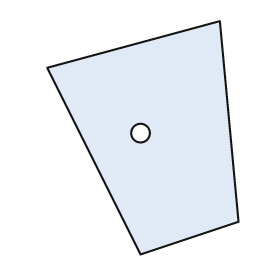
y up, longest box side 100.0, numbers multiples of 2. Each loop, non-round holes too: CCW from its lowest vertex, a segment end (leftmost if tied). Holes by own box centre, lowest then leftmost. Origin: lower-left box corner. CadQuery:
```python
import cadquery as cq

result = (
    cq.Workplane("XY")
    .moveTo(40.0, 0.0)
    .lineTo(82.0, 14.0)
    .lineTo(74.0, 100.0)
    .lineTo(0.0, 80.0)
    .close()
    .moveTo(40.0, 52.0)
    .circle(4.0)
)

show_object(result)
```